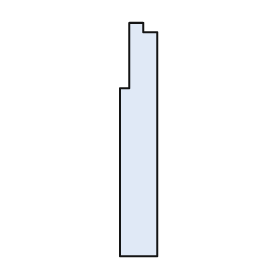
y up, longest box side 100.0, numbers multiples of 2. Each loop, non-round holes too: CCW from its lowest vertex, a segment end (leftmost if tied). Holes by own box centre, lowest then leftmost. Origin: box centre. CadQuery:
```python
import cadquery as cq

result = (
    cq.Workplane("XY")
    .moveTo(-8.0, -50.0)
    .lineTo(8.0, -50.0)
    .lineTo(8.0, 46.0)
    .lineTo(2.0, 46.0)
    .lineTo(2.0, 50.0)
    .lineTo(-4.0, 50.0)
    .lineTo(-4.0, 22.0)
    .lineTo(-8.0, 22.0)
    .close()
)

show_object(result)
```